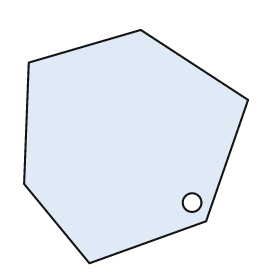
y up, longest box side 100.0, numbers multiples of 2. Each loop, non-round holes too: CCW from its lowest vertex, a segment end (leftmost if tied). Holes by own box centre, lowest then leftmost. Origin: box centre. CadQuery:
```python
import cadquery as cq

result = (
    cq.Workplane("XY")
    .moveTo(-20.0, -50.0)
    .lineTo(30.0, -32.0)
    .lineTo(48.0, 20.0)
    .lineTo(2.0, 50.0)
    .lineTo(-46.0, 36.0)
    .lineTo(-48.0, -16.0)
    .close()
    .moveTo(24.0, -24.0)
    .circle(4.0)
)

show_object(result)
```